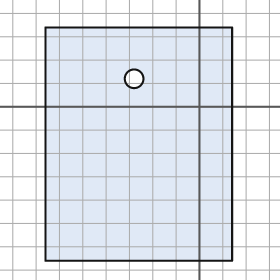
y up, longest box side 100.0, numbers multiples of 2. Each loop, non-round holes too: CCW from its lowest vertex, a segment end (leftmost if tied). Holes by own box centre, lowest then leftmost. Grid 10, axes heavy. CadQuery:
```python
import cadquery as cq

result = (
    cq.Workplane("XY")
    .moveTo(-66.0, -66.0)
    .lineTo(14.0, -66.0)
    .lineTo(14.0, 34.0)
    .lineTo(-66.0, 34.0)
    .close()
    .moveTo(-28.0, 12.0)
    .circle(4.0)
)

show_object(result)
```